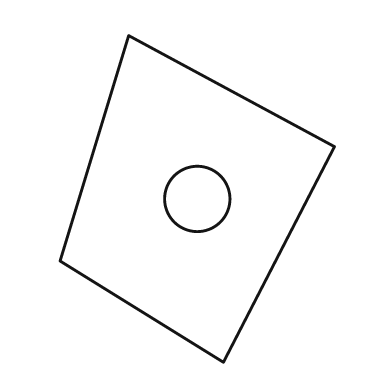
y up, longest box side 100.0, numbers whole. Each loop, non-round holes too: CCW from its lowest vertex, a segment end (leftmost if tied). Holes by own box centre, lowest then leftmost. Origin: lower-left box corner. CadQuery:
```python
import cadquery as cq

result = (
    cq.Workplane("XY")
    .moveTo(50.0, 0.0)
    .lineTo(84.0, 66.0)
    .lineTo(21.0, 100.0)
    .lineTo(0.0, 31.0)
    .close()
    .moveTo(42.0, 50.0)
    .circle(10.0)
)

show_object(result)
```